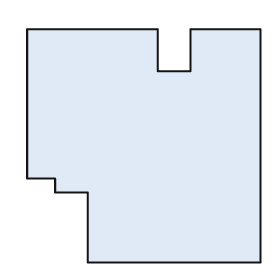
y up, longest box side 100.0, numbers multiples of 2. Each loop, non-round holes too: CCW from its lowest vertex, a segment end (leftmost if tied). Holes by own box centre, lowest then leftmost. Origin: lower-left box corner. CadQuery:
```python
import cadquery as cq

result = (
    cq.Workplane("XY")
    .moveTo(26.0, 0.0)
    .lineTo(100.0, 0.0)
    .lineTo(100.0, 100.0)
    .lineTo(70.0, 100.0)
    .lineTo(70.0, 82.0)
    .lineTo(56.0, 82.0)
    .lineTo(56.0, 100.0)
    .lineTo(0.0, 100.0)
    .lineTo(0.0, 36.0)
    .lineTo(12.0, 36.0)
    .lineTo(12.0, 30.0)
    .lineTo(26.0, 30.0)
    .close()
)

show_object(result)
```